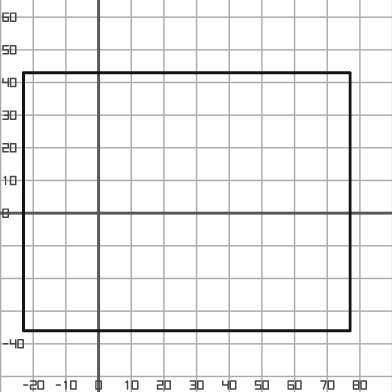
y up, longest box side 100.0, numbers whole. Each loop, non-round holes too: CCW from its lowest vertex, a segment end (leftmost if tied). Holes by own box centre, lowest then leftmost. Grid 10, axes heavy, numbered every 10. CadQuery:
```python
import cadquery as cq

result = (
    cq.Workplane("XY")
    .moveTo(-23.0, -36.0)
    .lineTo(77.0, -36.0)
    .lineTo(77.0, 43.0)
    .lineTo(-23.0, 43.0)
    .close()
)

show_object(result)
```